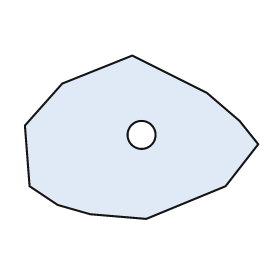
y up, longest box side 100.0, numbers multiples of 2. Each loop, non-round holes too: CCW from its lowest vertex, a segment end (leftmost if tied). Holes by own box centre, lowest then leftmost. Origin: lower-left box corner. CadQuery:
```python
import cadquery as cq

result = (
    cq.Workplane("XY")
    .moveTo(52.0, 0.0)
    .lineTo(86.0, 14.0)
    .lineTo(100.0, 32.0)
    .lineTo(92.0, 42.0)
    .lineTo(78.0, 54.0)
    .lineTo(46.0, 70.0)
    .lineTo(16.0, 58.0)
    .lineTo(0.0, 40.0)
    .lineTo(2.0, 14.0)
    .lineTo(14.0, 6.0)
    .lineTo(28.0, 2.0)
    .close()
    .moveTo(50.0, 36.0)
    .circle(6.0)
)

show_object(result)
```